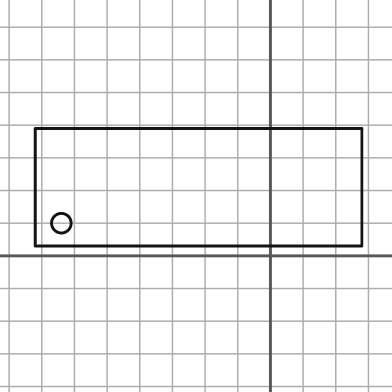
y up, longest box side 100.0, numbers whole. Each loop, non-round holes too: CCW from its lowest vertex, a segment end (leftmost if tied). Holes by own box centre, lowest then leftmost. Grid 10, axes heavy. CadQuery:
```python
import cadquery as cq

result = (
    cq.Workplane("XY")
    .moveTo(-72.0, 3.0)
    .lineTo(28.0, 3.0)
    .lineTo(28.0, 39.0)
    .lineTo(-72.0, 39.0)
    .close()
    .moveTo(-64.0, 10.0)
    .circle(3.0)
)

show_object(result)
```